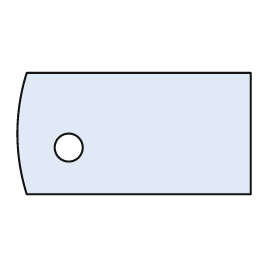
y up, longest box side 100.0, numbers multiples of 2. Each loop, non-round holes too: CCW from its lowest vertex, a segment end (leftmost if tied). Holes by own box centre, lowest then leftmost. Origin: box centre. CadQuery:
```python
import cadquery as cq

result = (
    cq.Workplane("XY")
    .moveTo(-46.0, -26.0)
    .lineTo(50.0, -26.0)
    .lineTo(50.0, 26.0)
    .lineTo(-46.0, 26.0)
    .threePointArc((-50.0, 0.0), (-46.0, -26.0))
    .close()
    .moveTo(-28.0, -6.0)
    .circle(6.0)
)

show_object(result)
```